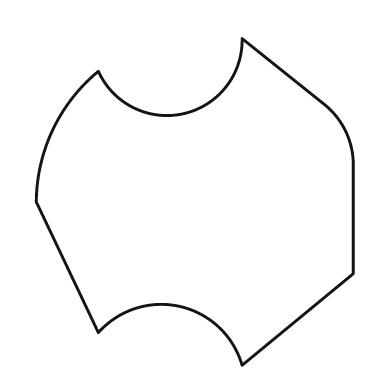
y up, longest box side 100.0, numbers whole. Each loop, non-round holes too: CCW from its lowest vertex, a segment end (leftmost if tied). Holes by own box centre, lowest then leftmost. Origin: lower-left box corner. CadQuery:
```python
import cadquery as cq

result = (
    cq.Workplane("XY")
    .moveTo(63.0, 0.0)
    .lineTo(97.0, 28.0)
    .lineTo(97.0, 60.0)
    .threePointArc((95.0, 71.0), (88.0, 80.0))
    .lineTo(63.0, 100.0)
    .threePointArc((45.0, 77.0), (19.0, 90.0))
    .threePointArc((5.0, 72.0), (0.0, 50.0))
    .lineTo(19.0, 10.0)
    .threePointArc((44.0, 18.0), (63.0, 0.0))
    .close()
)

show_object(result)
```